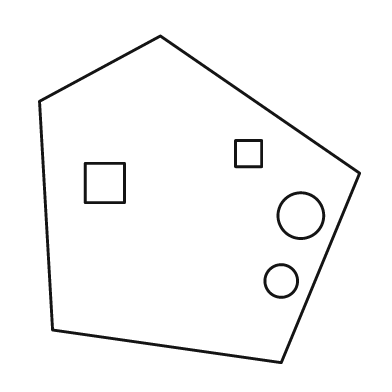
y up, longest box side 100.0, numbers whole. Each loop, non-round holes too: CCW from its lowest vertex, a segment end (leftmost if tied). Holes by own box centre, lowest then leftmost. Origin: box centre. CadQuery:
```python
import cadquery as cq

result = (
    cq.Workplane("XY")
    .moveTo(25.0, -50.0)
    .lineTo(49.0, 8.0)
    .lineTo(-12.0, 50.0)
    .lineTo(-49.0, 30.0)
    .lineTo(-45.0, -40.0)
    .close()
    .moveTo(25.0, -25.0)
    .circle(5.0)
    .moveTo(31.0, -5.0)
    .circle(7.0)
    .moveTo(-35.0, -1.0)
    .lineTo(-23.0, -1.0)
    .lineTo(-23.0, 11.0)
    .lineTo(-35.0, 11.0)
    .close()
    .moveTo(11.0, 10.0)
    .lineTo(19.0, 10.0)
    .lineTo(19.0, 18.0)
    .lineTo(11.0, 18.0)
    .close()
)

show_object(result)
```